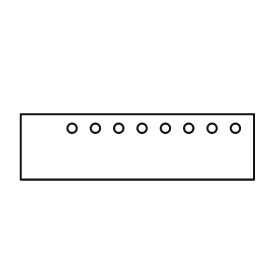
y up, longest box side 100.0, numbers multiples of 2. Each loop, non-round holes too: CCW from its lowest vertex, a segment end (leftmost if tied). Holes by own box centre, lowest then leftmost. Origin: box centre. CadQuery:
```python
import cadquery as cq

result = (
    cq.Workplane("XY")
    .moveTo(-50.0, -14.0)
    .lineTo(50.0, -14.0)
    .lineTo(50.0, 14.0)
    .lineTo(-50.0, 14.0)
    .close()
    .moveTo(-28.0, 8.0)
    .circle(2.0)
    .moveTo(-18.0, 8.0)
    .circle(2.0)
    .moveTo(-8.0, 8.0)
    .circle(2.0)
    .moveTo(2.0, 8.0)
    .circle(2.0)
    .moveTo(12.0, 8.0)
    .circle(2.0)
    .moveTo(22.0, 8.0)
    .circle(2.0)
    .moveTo(32.0, 8.0)
    .circle(2.0)
    .moveTo(42.0, 8.0)
    .circle(2.0)
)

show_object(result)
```